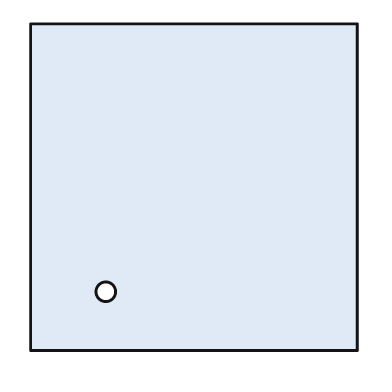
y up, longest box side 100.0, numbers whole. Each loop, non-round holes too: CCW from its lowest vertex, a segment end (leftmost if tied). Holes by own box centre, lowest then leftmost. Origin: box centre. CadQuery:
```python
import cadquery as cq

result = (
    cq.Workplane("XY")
    .moveTo(-50.0, -50.0)
    .lineTo(50.0, -50.0)
    .lineTo(50.0, 50.0)
    .lineTo(-50.0, 50.0)
    .close()
    .moveTo(-27.0, -32.0)
    .circle(3.0)
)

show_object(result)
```